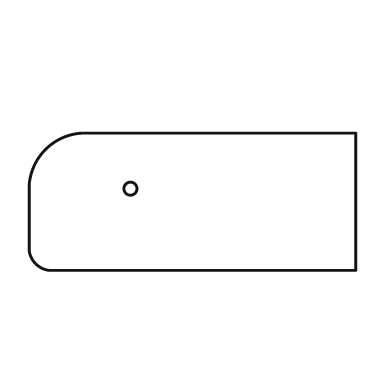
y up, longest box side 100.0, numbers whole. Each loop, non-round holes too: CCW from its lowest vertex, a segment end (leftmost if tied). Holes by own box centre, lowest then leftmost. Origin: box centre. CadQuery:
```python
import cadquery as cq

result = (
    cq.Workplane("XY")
    .moveTo(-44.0, -21.0)
    .lineTo(50.0, -21.0)
    .lineTo(50.0, 21.0)
    .lineTo(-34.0, 21.0)
    .threePointArc((-45.0, 16.0), (-50.0, 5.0))
    .lineTo(-50.0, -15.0)
    .threePointArc((-48.0, -19.0), (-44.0, -21.0))
    .close()
    .moveTo(-19.0, 4.0)
    .circle(2.0)
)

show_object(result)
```